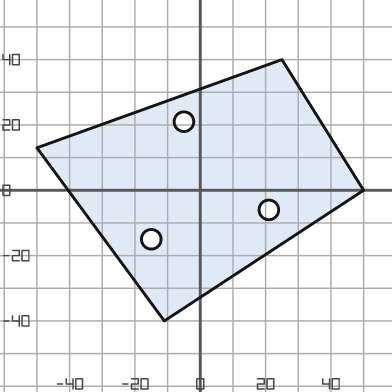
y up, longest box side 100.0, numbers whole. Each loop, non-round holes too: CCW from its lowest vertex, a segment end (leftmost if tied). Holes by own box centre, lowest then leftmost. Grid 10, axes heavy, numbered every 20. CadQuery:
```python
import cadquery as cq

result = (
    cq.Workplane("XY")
    .moveTo(-11.0, -40.0)
    .lineTo(50.0, 0.0)
    .lineTo(25.0, 40.0)
    .lineTo(-50.0, 13.0)
    .close()
    .moveTo(-15.0, -15.0)
    .circle(3.0)
    .moveTo(21.0, -6.0)
    .circle(3.0)
    .moveTo(-5.0, 21.0)
    .circle(3.0)
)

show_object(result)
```